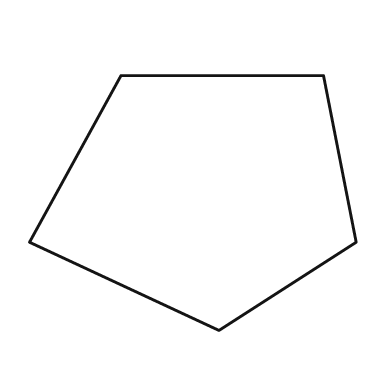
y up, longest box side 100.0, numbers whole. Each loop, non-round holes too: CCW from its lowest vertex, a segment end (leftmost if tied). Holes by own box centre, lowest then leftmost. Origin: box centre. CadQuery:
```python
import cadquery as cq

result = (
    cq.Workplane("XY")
    .moveTo(8.0, -39.0)
    .lineTo(50.0, -12.0)
    .lineTo(40.0, 39.0)
    .lineTo(-22.0, 39.0)
    .lineTo(-50.0, -12.0)
    .close()
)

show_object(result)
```